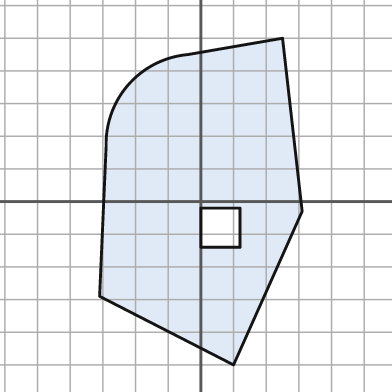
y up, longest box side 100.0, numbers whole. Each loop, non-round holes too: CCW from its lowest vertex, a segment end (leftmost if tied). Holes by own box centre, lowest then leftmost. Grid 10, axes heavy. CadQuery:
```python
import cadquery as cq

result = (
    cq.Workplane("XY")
    .moveTo(10.0, -50.0)
    .lineTo(31.0, -3.0)
    .lineTo(25.0, 50.0)
    .lineTo(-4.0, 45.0)
    .threePointArc((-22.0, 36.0), (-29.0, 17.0))
    .lineTo(-31.0, -29.0)
    .close()
    .moveTo(0.0, -14.0)
    .lineTo(12.0, -14.0)
    .lineTo(12.0, -2.0)
    .lineTo(0.0, -2.0)
    .close()
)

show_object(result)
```